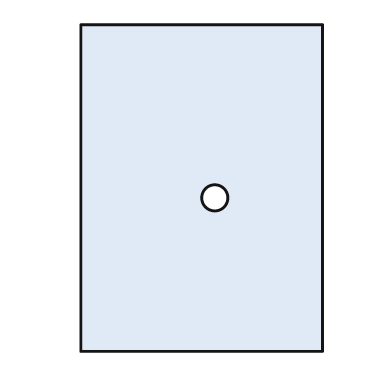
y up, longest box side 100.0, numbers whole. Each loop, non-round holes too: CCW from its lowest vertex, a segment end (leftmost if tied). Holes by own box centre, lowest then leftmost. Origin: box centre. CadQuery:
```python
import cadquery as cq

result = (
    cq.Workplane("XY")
    .moveTo(-37.0, -50.0)
    .lineTo(37.0, -50.0)
    .lineTo(37.0, 50.0)
    .lineTo(-37.0, 50.0)
    .close()
    .moveTo(4.0, -3.0)
    .circle(4.0)
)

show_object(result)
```